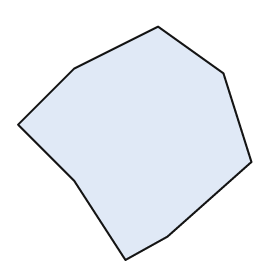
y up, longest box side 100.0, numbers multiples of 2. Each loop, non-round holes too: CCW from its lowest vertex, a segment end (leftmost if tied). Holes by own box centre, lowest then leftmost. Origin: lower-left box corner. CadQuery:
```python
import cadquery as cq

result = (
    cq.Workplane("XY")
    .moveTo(46.0, 0.0)
    .lineTo(64.0, 10.0)
    .lineTo(100.0, 42.0)
    .lineTo(88.0, 80.0)
    .lineTo(60.0, 100.0)
    .lineTo(24.0, 82.0)
    .lineTo(0.0, 58.0)
    .lineTo(24.0, 34.0)
    .close()
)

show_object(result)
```